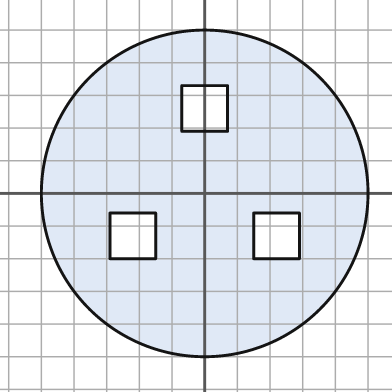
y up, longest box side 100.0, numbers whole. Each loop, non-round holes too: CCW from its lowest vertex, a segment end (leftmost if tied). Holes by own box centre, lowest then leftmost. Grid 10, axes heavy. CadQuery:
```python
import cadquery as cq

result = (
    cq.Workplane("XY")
    .moveTo(0.0, 0.0)
    .circle(50.0)
    .moveTo(-29.0, -20.0)
    .lineTo(-15.0, -20.0)
    .lineTo(-15.0, -6.0)
    .lineTo(-29.0, -6.0)
    .close()
    .moveTo(15.0, -20.0)
    .lineTo(29.0, -20.0)
    .lineTo(29.0, -6.0)
    .lineTo(15.0, -6.0)
    .close()
    .moveTo(-7.0, 19.0)
    .lineTo(7.0, 19.0)
    .lineTo(7.0, 33.0)
    .lineTo(-7.0, 33.0)
    .close()
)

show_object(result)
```